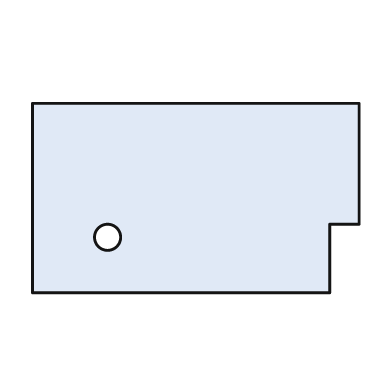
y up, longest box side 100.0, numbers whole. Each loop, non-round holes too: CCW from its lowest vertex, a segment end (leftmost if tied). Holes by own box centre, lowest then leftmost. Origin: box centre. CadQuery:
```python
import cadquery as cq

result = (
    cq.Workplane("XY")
    .moveTo(-50.0, -29.0)
    .lineTo(41.0, -29.0)
    .lineTo(41.0, -8.0)
    .lineTo(50.0, -8.0)
    .lineTo(50.0, 29.0)
    .lineTo(-50.0, 29.0)
    .close()
    .moveTo(-27.0, -12.0)
    .circle(4.0)
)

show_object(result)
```